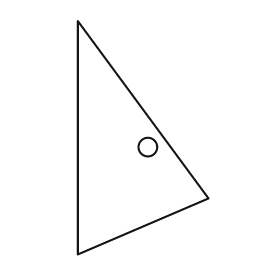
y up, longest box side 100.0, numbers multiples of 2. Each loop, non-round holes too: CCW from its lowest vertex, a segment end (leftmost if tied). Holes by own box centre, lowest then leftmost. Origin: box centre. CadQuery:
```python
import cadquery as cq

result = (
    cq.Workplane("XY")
    .moveTo(-28.0, -50.0)
    .lineTo(28.0, -26.0)
    .lineTo(-28.0, 50.0)
    .close()
    .moveTo(2.0, -4.0)
    .circle(4.0)
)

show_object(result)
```